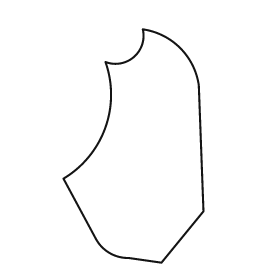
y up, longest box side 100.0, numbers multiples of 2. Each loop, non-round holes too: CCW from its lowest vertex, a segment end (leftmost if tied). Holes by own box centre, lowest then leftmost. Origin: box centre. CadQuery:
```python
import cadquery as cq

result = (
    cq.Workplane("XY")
    .moveTo(12.0, -50.0)
    .lineTo(30.0, -28.0)
    .lineTo(28.0, 26.0)
    .threePointArc((20.0, 42.0), (4.0, 50.0))
    .threePointArc((0.0, 38.0), (-12.0, 36.0))
    .threePointArc((-12.0, 8.0), (-30.0, -14.0))
    .lineTo(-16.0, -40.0)
    .threePointArc((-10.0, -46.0), (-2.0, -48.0))
    .close()
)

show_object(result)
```